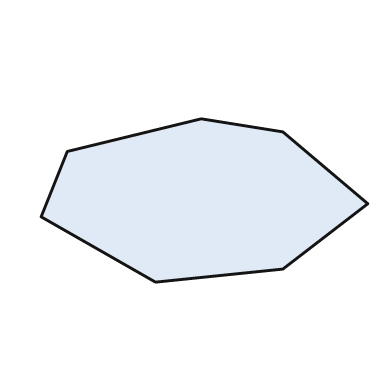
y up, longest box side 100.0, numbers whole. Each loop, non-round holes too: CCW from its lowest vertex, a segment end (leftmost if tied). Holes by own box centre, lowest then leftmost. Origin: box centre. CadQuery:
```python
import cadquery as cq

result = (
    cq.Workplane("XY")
    .moveTo(-15.0, -25.0)
    .lineTo(24.0, -21.0)
    .lineTo(50.0, -1.0)
    .lineTo(24.0, 21.0)
    .lineTo(-1.0, 25.0)
    .lineTo(-42.0, 15.0)
    .lineTo(-50.0, -5.0)
    .close()
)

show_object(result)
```